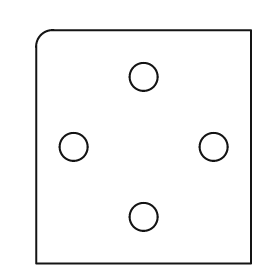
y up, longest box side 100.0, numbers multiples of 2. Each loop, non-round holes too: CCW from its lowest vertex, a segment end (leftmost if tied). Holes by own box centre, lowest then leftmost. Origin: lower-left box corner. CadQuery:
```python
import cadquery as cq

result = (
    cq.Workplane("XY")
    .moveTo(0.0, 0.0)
    .lineTo(92.0, 0.0)
    .lineTo(92.0, 100.0)
    .lineTo(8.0, 100.0)
    .threePointArc((2.0, 98.0), (0.0, 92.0))
    .close()
    .moveTo(46.0, 20.0)
    .circle(6.0)
    .moveTo(16.0, 50.0)
    .circle(6.0)
    .moveTo(76.0, 50.0)
    .circle(6.0)
    .moveTo(46.0, 80.0)
    .circle(6.0)
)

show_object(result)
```